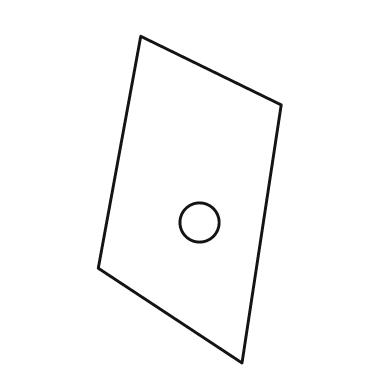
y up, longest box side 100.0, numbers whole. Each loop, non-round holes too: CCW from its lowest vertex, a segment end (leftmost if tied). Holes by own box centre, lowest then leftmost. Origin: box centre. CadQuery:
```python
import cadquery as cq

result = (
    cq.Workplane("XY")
    .moveTo(16.0, -50.0)
    .lineTo(28.0, 29.0)
    .lineTo(-15.0, 50.0)
    .lineTo(-28.0, -21.0)
    .close()
    .moveTo(3.0, -7.0)
    .circle(6.0)
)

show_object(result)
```